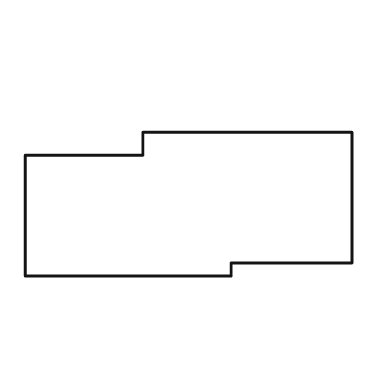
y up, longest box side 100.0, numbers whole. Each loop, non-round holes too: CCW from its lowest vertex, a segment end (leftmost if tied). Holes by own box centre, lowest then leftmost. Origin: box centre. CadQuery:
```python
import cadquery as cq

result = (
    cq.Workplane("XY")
    .moveTo(-50.0, -22.0)
    .lineTo(13.0, -22.0)
    .lineTo(13.0, -18.0)
    .lineTo(50.0, -18.0)
    .lineTo(50.0, 22.0)
    .lineTo(-14.0, 22.0)
    .lineTo(-14.0, 15.0)
    .lineTo(-50.0, 15.0)
    .close()
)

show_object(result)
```